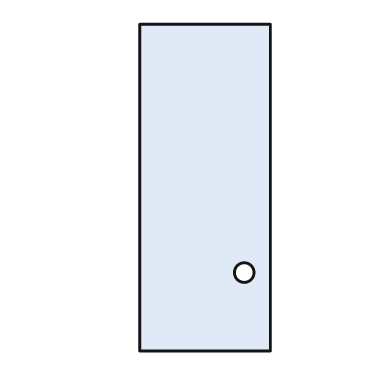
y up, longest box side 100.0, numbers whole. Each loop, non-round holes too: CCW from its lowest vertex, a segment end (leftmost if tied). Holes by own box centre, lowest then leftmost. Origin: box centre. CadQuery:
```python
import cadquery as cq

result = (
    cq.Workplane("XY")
    .moveTo(-20.0, -50.0)
    .lineTo(20.0, -50.0)
    .lineTo(20.0, 50.0)
    .lineTo(-20.0, 50.0)
    .close()
    .moveTo(12.0, -26.0)
    .circle(3.0)
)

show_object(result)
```